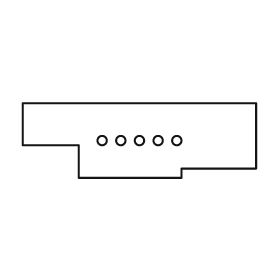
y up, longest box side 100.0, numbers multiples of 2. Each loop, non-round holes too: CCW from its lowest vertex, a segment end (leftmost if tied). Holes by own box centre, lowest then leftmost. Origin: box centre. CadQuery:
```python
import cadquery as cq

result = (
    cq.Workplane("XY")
    .moveTo(-26.0, -16.0)
    .lineTo(18.0, -16.0)
    .lineTo(18.0, -12.0)
    .lineTo(50.0, -12.0)
    .lineTo(50.0, 16.0)
    .lineTo(-50.0, 16.0)
    .lineTo(-50.0, -2.0)
    .lineTo(-26.0, -2.0)
    .close()
    .moveTo(-16.0, 0.0)
    .circle(2.0)
    .moveTo(-8.0, 0.0)
    .circle(2.0)
    .moveTo(0.0, 0.0)
    .circle(2.0)
    .moveTo(8.0, 0.0)
    .circle(2.0)
    .moveTo(16.0, 0.0)
    .circle(2.0)
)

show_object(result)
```